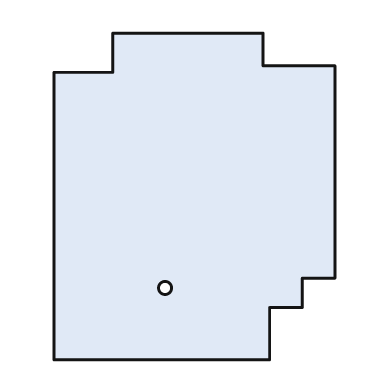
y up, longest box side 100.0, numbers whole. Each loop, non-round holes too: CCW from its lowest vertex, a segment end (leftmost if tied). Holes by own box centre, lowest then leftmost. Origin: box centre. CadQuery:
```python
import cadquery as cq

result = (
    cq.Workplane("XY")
    .moveTo(-43.0, -50.0)
    .lineTo(23.0, -50.0)
    .lineTo(23.0, -34.0)
    .lineTo(33.0, -34.0)
    .lineTo(33.0, -25.0)
    .lineTo(43.0, -25.0)
    .lineTo(43.0, 40.0)
    .lineTo(21.0, 40.0)
    .lineTo(21.0, 50.0)
    .lineTo(-25.0, 50.0)
    .lineTo(-25.0, 38.0)
    .lineTo(-43.0, 38.0)
    .close()
    .moveTo(-9.0, -28.0)
    .circle(2.0)
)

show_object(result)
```